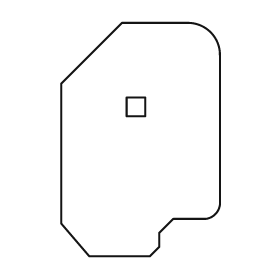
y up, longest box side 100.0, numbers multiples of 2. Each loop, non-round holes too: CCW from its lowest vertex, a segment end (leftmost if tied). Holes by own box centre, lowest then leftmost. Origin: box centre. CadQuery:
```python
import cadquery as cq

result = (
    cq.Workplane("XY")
    .moveTo(-22.0, -50.0)
    .lineTo(4.0, -50.0)
    .lineTo(8.0, -46.0)
    .lineTo(8.0, -40.0)
    .lineTo(14.0, -34.0)
    .lineTo(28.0, -34.0)
    .threePointArc((32.0, -32.0), (34.0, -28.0))
    .lineTo(34.0, 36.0)
    .threePointArc((30.0, 46.0), (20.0, 50.0))
    .lineTo(-8.0, 50.0)
    .lineTo(-34.0, 24.0)
    .lineTo(-34.0, -36.0)
    .close()
    .moveTo(-6.0, 10.0)
    .lineTo(2.0, 10.0)
    .lineTo(2.0, 18.0)
    .lineTo(-6.0, 18.0)
    .close()
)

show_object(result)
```